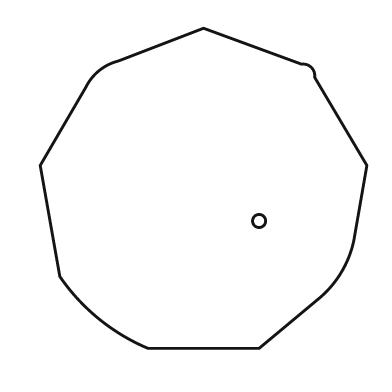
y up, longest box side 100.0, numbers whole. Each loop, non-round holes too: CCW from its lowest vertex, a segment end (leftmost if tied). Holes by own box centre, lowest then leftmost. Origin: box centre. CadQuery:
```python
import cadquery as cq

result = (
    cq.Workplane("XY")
    .moveTo(-17.0, -49.0)
    .lineTo(17.0, -49.0)
    .lineTo(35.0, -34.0)
    .threePointArc((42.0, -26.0), (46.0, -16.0))
    .lineTo(50.0, 7.0)
    .lineTo(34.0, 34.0)
    .threePointArc((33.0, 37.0), (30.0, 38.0))
    .lineTo(0.0, 49.0)
    .lineTo(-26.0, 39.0)
    .threePointArc((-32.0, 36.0), (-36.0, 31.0))
    .lineTo(-50.0, 7.0)
    .lineTo(-44.0, -27.0)
    .threePointArc((-32.0, -40.0), (-17.0, -49.0))
    .close()
    .moveTo(17.0, -10.0)
    .circle(2.0)
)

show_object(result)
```